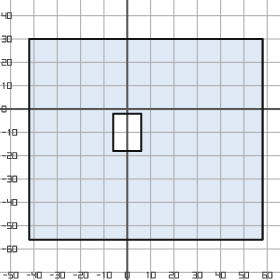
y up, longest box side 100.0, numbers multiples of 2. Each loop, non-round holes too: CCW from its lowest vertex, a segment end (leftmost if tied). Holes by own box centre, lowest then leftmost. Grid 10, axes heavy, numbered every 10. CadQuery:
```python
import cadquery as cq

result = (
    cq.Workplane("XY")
    .moveTo(-42.0, -56.0)
    .lineTo(58.0, -56.0)
    .lineTo(58.0, 30.0)
    .lineTo(-42.0, 30.0)
    .close()
    .moveTo(-6.0, -18.0)
    .lineTo(6.0, -18.0)
    .lineTo(6.0, -2.0)
    .lineTo(-6.0, -2.0)
    .close()
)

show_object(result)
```